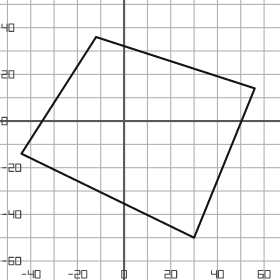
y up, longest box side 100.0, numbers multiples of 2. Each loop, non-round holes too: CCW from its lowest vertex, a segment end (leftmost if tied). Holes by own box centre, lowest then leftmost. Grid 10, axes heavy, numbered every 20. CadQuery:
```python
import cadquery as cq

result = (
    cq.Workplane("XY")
    .moveTo(30.0, -50.0)
    .lineTo(56.0, 14.0)
    .lineTo(-12.0, 36.0)
    .lineTo(-44.0, -14.0)
    .close()
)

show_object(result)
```